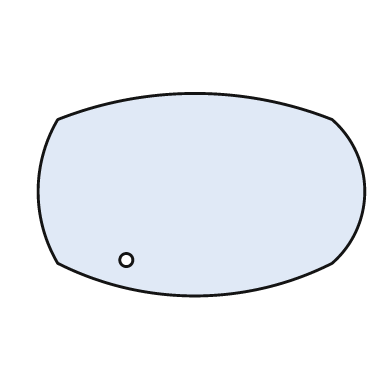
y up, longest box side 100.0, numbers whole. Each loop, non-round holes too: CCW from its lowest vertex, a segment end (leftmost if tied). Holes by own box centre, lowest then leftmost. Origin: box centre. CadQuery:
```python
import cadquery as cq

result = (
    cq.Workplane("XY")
    .moveTo(-44.0, -21.0)
    .threePointArc((-2.0, -31.0), (40.0, -21.0))
    .threePointArc((50.0, 1.0), (40.0, 23.0))
    .threePointArc((-2.0, 31.0), (-44.0, 23.0))
    .threePointArc((-50.0, 1.0), (-44.0, -21.0))
    .close()
    .moveTo(-23.0, -20.0)
    .circle(2.0)
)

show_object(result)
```